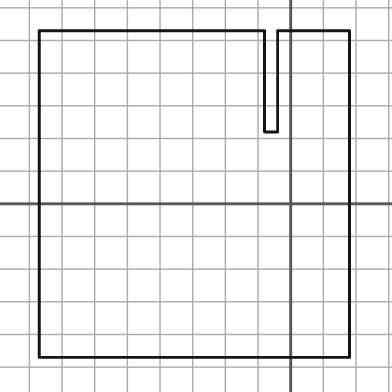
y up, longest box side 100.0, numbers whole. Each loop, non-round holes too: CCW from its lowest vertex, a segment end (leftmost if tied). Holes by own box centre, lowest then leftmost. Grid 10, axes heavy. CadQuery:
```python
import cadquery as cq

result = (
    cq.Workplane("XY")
    .moveTo(-77.0, -47.0)
    .lineTo(18.0, -47.0)
    .lineTo(18.0, 53.0)
    .lineTo(-4.0, 53.0)
    .lineTo(-4.0, 22.0)
    .lineTo(-8.0, 22.0)
    .lineTo(-8.0, 53.0)
    .lineTo(-77.0, 53.0)
    .close()
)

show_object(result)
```